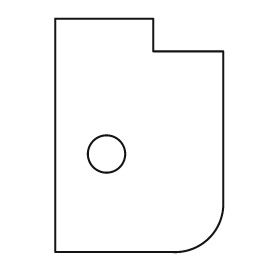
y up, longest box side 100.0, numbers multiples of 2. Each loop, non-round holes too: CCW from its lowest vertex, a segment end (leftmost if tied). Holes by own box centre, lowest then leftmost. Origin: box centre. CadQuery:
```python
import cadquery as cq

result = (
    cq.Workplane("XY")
    .moveTo(-36.0, -50.0)
    .lineTo(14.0, -50.0)
    .threePointArc((30.0, -44.0), (36.0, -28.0))
    .lineTo(36.0, 36.0)
    .lineTo(6.0, 36.0)
    .lineTo(6.0, 50.0)
    .lineTo(-36.0, 50.0)
    .close()
    .moveTo(-14.0, -8.0)
    .circle(8.0)
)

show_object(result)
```